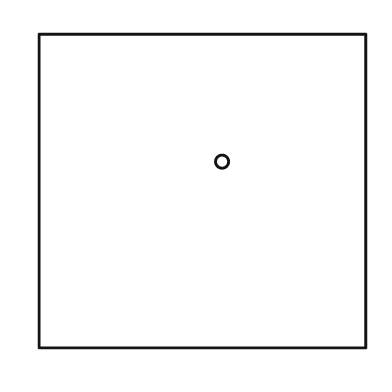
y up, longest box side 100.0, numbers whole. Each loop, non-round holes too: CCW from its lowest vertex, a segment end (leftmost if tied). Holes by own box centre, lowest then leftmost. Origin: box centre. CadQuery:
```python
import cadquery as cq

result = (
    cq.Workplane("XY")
    .moveTo(-50.0, -48.0)
    .lineTo(50.0, -48.0)
    .lineTo(50.0, 48.0)
    .lineTo(-50.0, 48.0)
    .close()
    .moveTo(6.0, 9.0)
    .circle(2.0)
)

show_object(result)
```